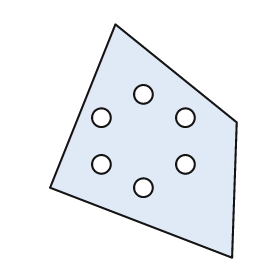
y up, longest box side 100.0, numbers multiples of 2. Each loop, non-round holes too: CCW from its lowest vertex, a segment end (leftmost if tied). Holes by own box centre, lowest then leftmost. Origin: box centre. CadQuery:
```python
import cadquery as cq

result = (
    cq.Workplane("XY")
    .moveTo(38.0, -50.0)
    .lineTo(40.0, 8.0)
    .lineTo(-12.0, 50.0)
    .lineTo(-40.0, -20.0)
    .close()
    .moveTo(0.0, -20.0)
    .circle(4.0)
    .moveTo(-18.0, -10.0)
    .circle(4.0)
    .moveTo(18.0, -10.0)
    .circle(4.0)
    .moveTo(-18.0, 10.0)
    .circle(4.0)
    .moveTo(18.0, 10.0)
    .circle(4.0)
    .moveTo(0.0, 20.0)
    .circle(4.0)
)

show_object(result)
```